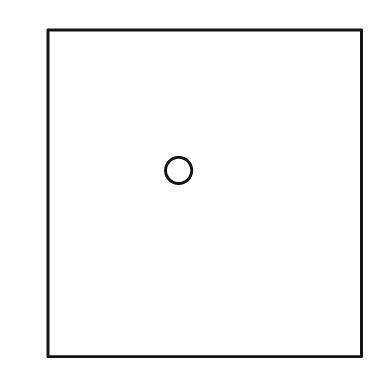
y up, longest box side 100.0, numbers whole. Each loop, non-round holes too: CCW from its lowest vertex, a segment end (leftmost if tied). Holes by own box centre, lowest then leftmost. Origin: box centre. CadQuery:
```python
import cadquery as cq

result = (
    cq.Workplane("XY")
    .moveTo(-48.0, -50.0)
    .lineTo(48.0, -50.0)
    .lineTo(48.0, 50.0)
    .lineTo(-48.0, 50.0)
    .close()
    .moveTo(-8.0, 7.0)
    .circle(4.0)
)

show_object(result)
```